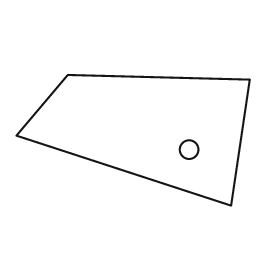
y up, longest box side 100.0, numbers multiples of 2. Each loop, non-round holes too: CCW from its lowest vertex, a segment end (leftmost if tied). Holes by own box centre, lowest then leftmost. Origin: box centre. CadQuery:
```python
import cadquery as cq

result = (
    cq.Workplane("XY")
    .moveTo(42.0, -28.0)
    .lineTo(50.0, 26.0)
    .lineTo(-28.0, 28.0)
    .lineTo(-50.0, 2.0)
    .close()
    .moveTo(24.0, -4.0)
    .circle(4.0)
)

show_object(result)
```